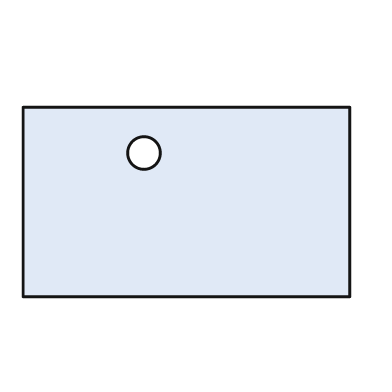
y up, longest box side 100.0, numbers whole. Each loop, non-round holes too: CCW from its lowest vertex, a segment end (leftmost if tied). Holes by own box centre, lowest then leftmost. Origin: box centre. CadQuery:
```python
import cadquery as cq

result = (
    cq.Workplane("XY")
    .moveTo(-50.0, -29.0)
    .lineTo(50.0, -29.0)
    .lineTo(50.0, 29.0)
    .lineTo(-50.0, 29.0)
    .close()
    .moveTo(-13.0, 15.0)
    .circle(5.0)
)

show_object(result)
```